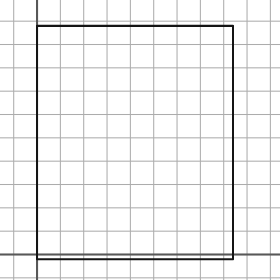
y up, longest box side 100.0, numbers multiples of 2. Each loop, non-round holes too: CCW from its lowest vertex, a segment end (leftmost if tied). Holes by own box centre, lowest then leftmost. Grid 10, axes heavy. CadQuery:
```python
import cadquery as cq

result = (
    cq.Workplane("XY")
    .moveTo(0.0, -2.0)
    .lineTo(84.0, -2.0)
    .lineTo(84.0, 98.0)
    .lineTo(0.0, 98.0)
    .close()
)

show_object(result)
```